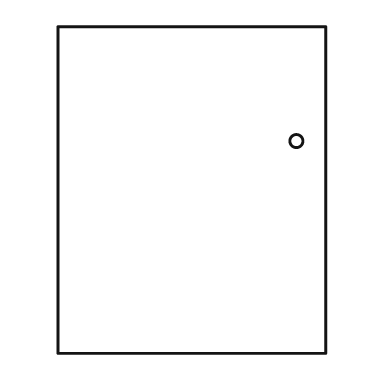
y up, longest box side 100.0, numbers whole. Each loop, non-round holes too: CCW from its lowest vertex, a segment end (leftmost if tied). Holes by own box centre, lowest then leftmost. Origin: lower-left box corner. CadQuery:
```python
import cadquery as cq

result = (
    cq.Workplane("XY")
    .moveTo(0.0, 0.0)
    .lineTo(82.0, 0.0)
    .lineTo(82.0, 100.0)
    .lineTo(0.0, 100.0)
    .close()
    .moveTo(73.0, 65.0)
    .circle(2.0)
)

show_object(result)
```